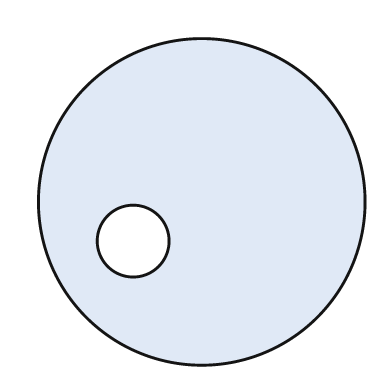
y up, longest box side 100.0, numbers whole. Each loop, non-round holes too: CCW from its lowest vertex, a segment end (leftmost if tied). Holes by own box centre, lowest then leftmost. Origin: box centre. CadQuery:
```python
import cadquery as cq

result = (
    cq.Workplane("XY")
    .moveTo(0.0, 0.0)
    .circle(50.0)
    .moveTo(-21.0, -12.0)
    .circle(11.0)
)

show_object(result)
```